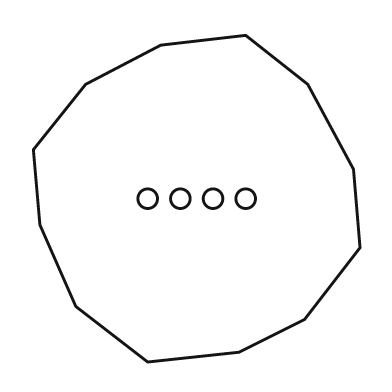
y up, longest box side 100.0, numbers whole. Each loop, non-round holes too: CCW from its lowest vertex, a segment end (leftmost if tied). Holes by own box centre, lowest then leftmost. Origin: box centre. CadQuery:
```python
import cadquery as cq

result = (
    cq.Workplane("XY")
    .moveTo(-15.0, -50.0)
    .lineTo(13.0, -47.0)
    .lineTo(33.0, -37.0)
    .lineTo(50.0, -15.0)
    .lineTo(48.0, 9.0)
    .lineTo(34.0, 35.0)
    .lineTo(15.0, 50.0)
    .lineTo(-11.0, 47.0)
    .lineTo(-34.0, 35.0)
    .lineTo(-50.0, 15.0)
    .lineTo(-48.0, -8.0)
    .lineTo(-37.0, -33.0)
    .close()
    .moveTo(-15.0, 0.0)
    .circle(3.0)
    .moveTo(-5.0, 0.0)
    .circle(3.0)
    .moveTo(5.0, 0.0)
    .circle(3.0)
    .moveTo(15.0, 0.0)
    .circle(3.0)
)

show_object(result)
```